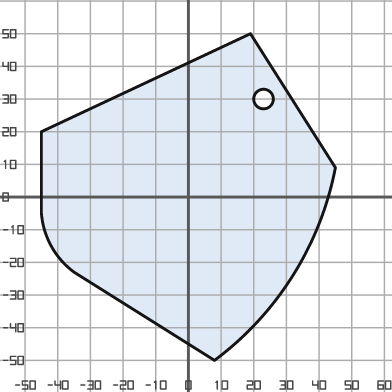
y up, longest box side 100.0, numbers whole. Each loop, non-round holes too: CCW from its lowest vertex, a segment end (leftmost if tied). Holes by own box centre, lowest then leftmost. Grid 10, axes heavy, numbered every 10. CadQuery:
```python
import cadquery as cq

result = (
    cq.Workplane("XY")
    .moveTo(8.0, -50.0)
    .threePointArc((32.0, -24.0), (45.0, 9.0))
    .lineTo(19.0, 50.0)
    .lineTo(-45.0, 20.0)
    .lineTo(-45.0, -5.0)
    .threePointArc((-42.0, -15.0), (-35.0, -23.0))
    .close()
    .moveTo(23.0, 30.0)
    .circle(3.0)
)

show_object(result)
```